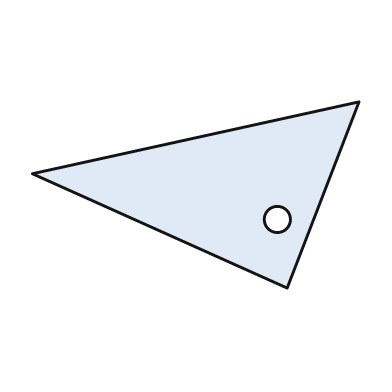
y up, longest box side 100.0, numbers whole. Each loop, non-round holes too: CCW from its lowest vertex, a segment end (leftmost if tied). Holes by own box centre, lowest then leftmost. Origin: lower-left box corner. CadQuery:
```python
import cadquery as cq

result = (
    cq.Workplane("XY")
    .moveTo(78.0, 0.0)
    .lineTo(100.0, 57.0)
    .lineTo(0.0, 35.0)
    .close()
    .moveTo(75.0, 21.0)
    .circle(4.0)
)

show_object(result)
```